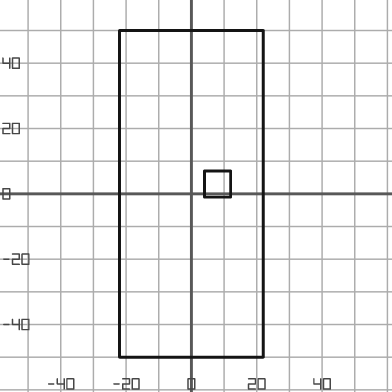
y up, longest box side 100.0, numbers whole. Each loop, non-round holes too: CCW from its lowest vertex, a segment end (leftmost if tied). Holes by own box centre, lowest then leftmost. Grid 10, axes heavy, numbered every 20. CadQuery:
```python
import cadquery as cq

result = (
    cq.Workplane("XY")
    .moveTo(-22.0, -50.0)
    .lineTo(22.0, -50.0)
    .lineTo(22.0, 50.0)
    .lineTo(-22.0, 50.0)
    .close()
    .moveTo(4.0, -1.0)
    .lineTo(12.0, -1.0)
    .lineTo(12.0, 7.0)
    .lineTo(4.0, 7.0)
    .close()
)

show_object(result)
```